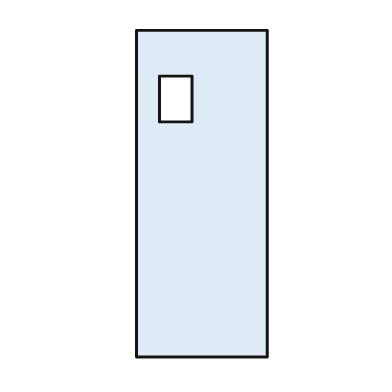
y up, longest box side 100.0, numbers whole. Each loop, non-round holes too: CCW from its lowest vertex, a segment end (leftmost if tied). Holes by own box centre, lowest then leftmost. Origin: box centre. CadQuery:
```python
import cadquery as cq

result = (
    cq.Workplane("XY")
    .moveTo(-20.0, -50.0)
    .lineTo(20.0, -50.0)
    .lineTo(20.0, 50.0)
    .lineTo(-20.0, 50.0)
    .close()
    .moveTo(-13.0, 22.0)
    .lineTo(-3.0, 22.0)
    .lineTo(-3.0, 36.0)
    .lineTo(-13.0, 36.0)
    .close()
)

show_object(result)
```